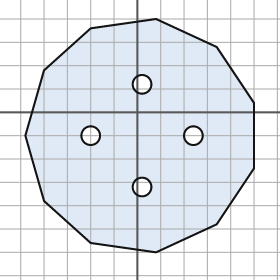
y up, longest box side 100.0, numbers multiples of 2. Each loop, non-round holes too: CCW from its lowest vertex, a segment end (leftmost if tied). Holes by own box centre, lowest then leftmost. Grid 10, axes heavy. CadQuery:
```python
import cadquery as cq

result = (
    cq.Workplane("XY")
    .moveTo(8.0, -60.0)
    .lineTo(34.0, -48.0)
    .lineTo(50.0, -24.0)
    .lineTo(50.0, 4.0)
    .lineTo(34.0, 28.0)
    .lineTo(8.0, 40.0)
    .lineTo(-20.0, 36.0)
    .lineTo(-40.0, 18.0)
    .lineTo(-48.0, -10.0)
    .lineTo(-40.0, -38.0)
    .lineTo(-20.0, -56.0)
    .close()
    .moveTo(2.0, -32.0)
    .circle(4.0)
    .moveTo(-20.0, -10.0)
    .circle(4.0)
    .moveTo(24.0, -10.0)
    .circle(4.0)
    .moveTo(2.0, 12.0)
    .circle(4.0)
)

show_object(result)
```